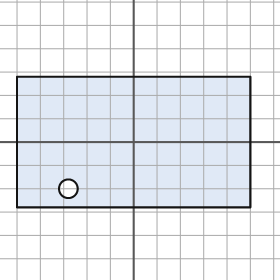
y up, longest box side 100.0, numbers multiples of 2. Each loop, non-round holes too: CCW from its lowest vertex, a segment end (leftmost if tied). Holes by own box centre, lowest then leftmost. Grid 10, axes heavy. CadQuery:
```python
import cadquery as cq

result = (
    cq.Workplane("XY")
    .moveTo(-50.0, -28.0)
    .lineTo(50.0, -28.0)
    .lineTo(50.0, 28.0)
    .lineTo(-50.0, 28.0)
    .close()
    .moveTo(-28.0, -20.0)
    .circle(4.0)
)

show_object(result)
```